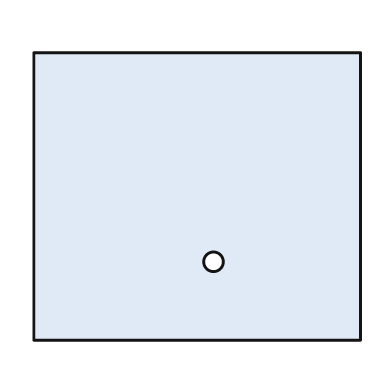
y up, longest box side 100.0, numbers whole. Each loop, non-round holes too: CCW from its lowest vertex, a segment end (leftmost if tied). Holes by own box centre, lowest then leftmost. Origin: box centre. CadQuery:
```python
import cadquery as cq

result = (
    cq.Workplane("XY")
    .moveTo(-50.0, -44.0)
    .lineTo(50.0, -44.0)
    .lineTo(50.0, 44.0)
    .lineTo(-50.0, 44.0)
    .close()
    .moveTo(5.0, -20.0)
    .circle(3.0)
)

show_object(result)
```